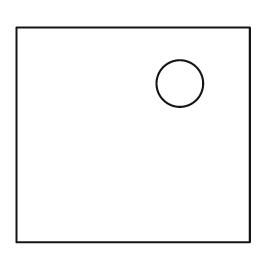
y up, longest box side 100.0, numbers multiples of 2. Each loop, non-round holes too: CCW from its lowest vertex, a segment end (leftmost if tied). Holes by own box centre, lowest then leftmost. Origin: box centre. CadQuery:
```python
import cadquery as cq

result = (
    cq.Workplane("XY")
    .moveTo(-50.0, -46.0)
    .lineTo(50.0, -46.0)
    .lineTo(50.0, 46.0)
    .lineTo(-50.0, 46.0)
    .close()
    .moveTo(20.0, 22.0)
    .circle(10.0)
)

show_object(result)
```